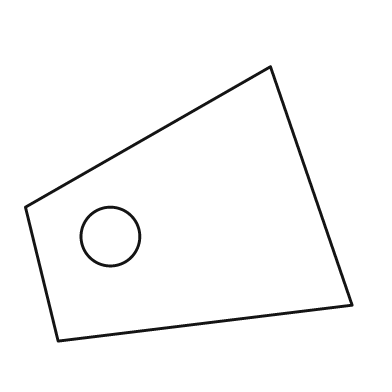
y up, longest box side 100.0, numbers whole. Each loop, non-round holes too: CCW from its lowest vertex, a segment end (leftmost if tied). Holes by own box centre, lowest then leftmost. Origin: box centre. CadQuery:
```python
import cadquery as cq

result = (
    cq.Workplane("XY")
    .moveTo(-40.0, -42.0)
    .lineTo(50.0, -31.0)
    .lineTo(25.0, 42.0)
    .lineTo(-50.0, -1.0)
    .close()
    .moveTo(-24.0, -10.0)
    .circle(9.0)
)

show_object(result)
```